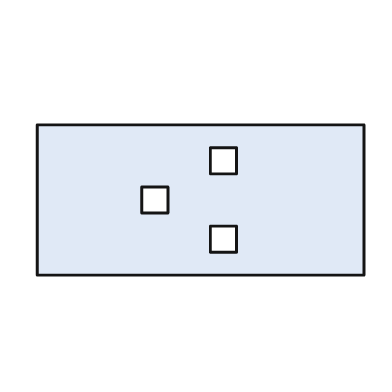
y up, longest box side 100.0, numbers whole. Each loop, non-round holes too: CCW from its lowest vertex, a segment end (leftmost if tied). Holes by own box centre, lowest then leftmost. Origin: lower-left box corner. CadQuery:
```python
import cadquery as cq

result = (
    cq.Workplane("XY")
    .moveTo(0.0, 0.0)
    .lineTo(100.0, 0.0)
    .lineTo(100.0, 46.0)
    .lineTo(0.0, 46.0)
    .close()
    .moveTo(53.0, 7.0)
    .lineTo(61.0, 7.0)
    .lineTo(61.0, 15.0)
    .lineTo(53.0, 15.0)
    .close()
    .moveTo(32.0, 19.0)
    .lineTo(40.0, 19.0)
    .lineTo(40.0, 27.0)
    .lineTo(32.0, 27.0)
    .close()
    .moveTo(53.0, 31.0)
    .lineTo(61.0, 31.0)
    .lineTo(61.0, 39.0)
    .lineTo(53.0, 39.0)
    .close()
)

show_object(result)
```